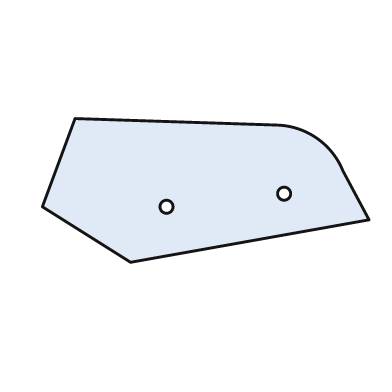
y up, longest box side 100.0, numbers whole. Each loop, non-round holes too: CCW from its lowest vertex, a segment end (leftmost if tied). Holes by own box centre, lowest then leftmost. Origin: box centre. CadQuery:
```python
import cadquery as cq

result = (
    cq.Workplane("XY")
    .moveTo(-23.0, -22.0)
    .lineTo(50.0, -9.0)
    .lineTo(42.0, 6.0)
    .threePointArc((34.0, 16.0), (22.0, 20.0))
    .lineTo(-40.0, 22.0)
    .lineTo(-50.0, -5.0)
    .close()
    .moveTo(-12.0, -5.0)
    .circle(2.0)
    .moveTo(24.0, -1.0)
    .circle(2.0)
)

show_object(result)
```